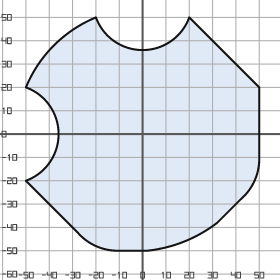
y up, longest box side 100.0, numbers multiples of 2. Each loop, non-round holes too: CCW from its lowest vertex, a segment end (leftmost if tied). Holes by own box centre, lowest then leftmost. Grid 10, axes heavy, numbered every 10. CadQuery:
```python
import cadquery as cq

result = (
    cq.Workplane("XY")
    .moveTo(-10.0, -50.0)
    .lineTo(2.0, -50.0)
    .threePointArc((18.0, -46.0), (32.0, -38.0))
    .lineTo(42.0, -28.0)
    .threePointArc((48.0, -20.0), (50.0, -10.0))
    .lineTo(50.0, 20.0)
    .lineTo(20.0, 50.0)
    .threePointArc((0.0, 36.0), (-20.0, 50.0))
    .threePointArc((-38.0, 38.0), (-50.0, 20.0))
    .threePointArc((-36.0, 0.0), (-50.0, -20.0))
    .lineTo(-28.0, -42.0)
    .threePointArc((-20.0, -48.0), (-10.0, -50.0))
    .close()
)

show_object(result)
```